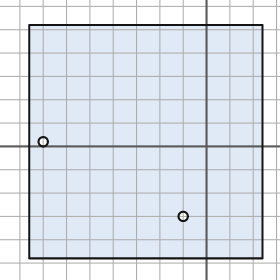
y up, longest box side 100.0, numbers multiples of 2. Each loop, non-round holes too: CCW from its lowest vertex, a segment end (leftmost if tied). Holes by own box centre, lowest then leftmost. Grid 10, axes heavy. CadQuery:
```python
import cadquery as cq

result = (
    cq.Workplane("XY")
    .moveTo(-76.0, -48.0)
    .lineTo(24.0, -48.0)
    .lineTo(24.0, 52.0)
    .lineTo(-76.0, 52.0)
    .close()
    .moveTo(-10.0, -30.0)
    .circle(2.0)
    .moveTo(-70.0, 2.0)
    .circle(2.0)
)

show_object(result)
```